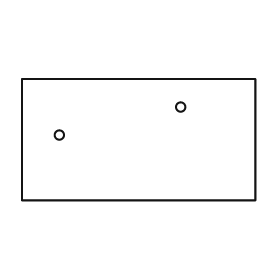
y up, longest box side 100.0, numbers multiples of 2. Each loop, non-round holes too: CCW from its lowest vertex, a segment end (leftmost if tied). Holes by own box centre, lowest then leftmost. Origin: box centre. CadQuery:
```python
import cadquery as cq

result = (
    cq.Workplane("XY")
    .moveTo(-50.0, -26.0)
    .lineTo(50.0, -26.0)
    .lineTo(50.0, 26.0)
    .lineTo(-50.0, 26.0)
    .close()
    .moveTo(-34.0, 2.0)
    .circle(2.0)
    .moveTo(18.0, 14.0)
    .circle(2.0)
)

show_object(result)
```